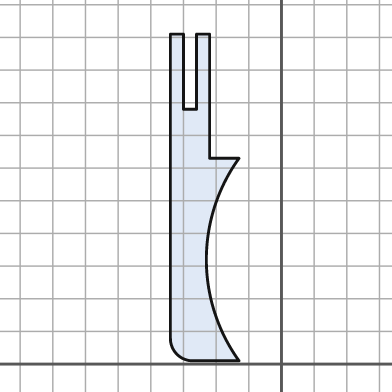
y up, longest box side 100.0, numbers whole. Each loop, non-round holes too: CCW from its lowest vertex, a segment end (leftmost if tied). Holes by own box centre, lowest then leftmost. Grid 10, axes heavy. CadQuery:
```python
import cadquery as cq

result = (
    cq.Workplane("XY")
    .moveTo(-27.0, 1.0)
    .lineTo(-13.0, 1.0)
    .threePointArc((-23.0, 32.0), (-13.0, 63.0))
    .lineTo(-22.0, 63.0)
    .lineTo(-22.0, 101.0)
    .lineTo(-26.0, 101.0)
    .lineTo(-26.0, 78.0)
    .lineTo(-30.0, 78.0)
    .lineTo(-30.0, 101.0)
    .lineTo(-34.0, 101.0)
    .lineTo(-34.0, 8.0)
    .threePointArc((-32.0, 3.0), (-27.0, 1.0))
    .close()
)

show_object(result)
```